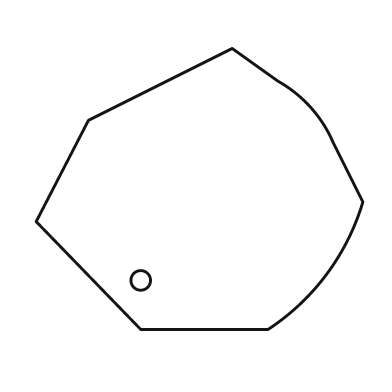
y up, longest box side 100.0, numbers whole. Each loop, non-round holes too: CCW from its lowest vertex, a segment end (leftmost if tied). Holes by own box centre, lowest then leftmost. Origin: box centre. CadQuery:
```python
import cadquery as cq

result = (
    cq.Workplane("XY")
    .moveTo(-18.0, -43.0)
    .lineTo(21.0, -43.0)
    .threePointArc((39.0, -26.0), (50.0, -4.0))
    .lineTo(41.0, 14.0)
    .threePointArc((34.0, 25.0), (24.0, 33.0))
    .lineTo(10.0, 43.0)
    .lineTo(-34.0, 21.0)
    .lineTo(-50.0, -10.0)
    .close()
    .moveTo(-18.0, -28.0)
    .circle(3.0)
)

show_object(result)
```